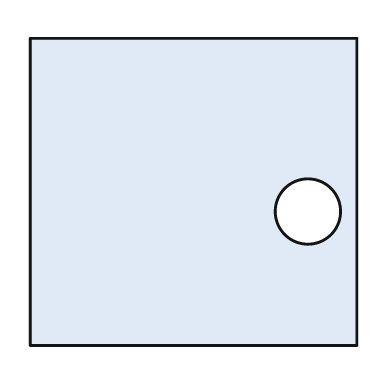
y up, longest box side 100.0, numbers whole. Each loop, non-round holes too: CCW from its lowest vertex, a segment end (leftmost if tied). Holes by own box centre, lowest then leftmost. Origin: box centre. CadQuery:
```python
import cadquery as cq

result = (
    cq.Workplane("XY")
    .moveTo(-50.0, -47.0)
    .lineTo(50.0, -47.0)
    .lineTo(50.0, 47.0)
    .lineTo(-50.0, 47.0)
    .close()
    .moveTo(35.0, -6.0)
    .circle(10.0)
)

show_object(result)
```